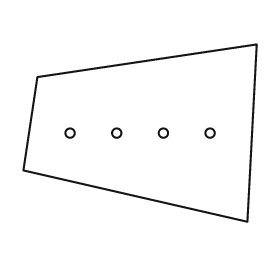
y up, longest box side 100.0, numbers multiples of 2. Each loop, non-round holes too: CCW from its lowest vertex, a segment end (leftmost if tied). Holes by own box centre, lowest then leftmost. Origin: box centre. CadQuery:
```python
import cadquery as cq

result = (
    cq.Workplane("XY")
    .moveTo(46.0, -38.0)
    .lineTo(50.0, 38.0)
    .lineTo(-44.0, 24.0)
    .lineTo(-50.0, -16.0)
    .close()
    .moveTo(-30.0, 0.0)
    .circle(2.0)
    .moveTo(-10.0, 0.0)
    .circle(2.0)
    .moveTo(10.0, 0.0)
    .circle(2.0)
    .moveTo(30.0, 0.0)
    .circle(2.0)
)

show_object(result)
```